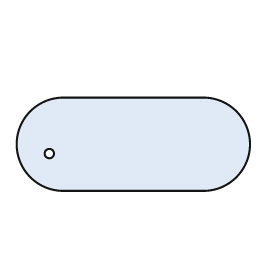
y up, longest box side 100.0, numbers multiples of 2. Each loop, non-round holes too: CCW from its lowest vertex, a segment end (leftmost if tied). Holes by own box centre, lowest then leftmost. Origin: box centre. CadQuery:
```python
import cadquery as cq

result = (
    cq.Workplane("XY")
    .moveTo(-30.0, -20.0)
    .lineTo(30.0, -20.0)
    .threePointArc((50.0, 0.0), (30.0, 20.0))
    .lineTo(-30.0, 20.0)
    .threePointArc((-50.0, 0.0), (-30.0, -20.0))
    .close()
    .moveTo(-36.0, -4.0)
    .circle(2.0)
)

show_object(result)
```